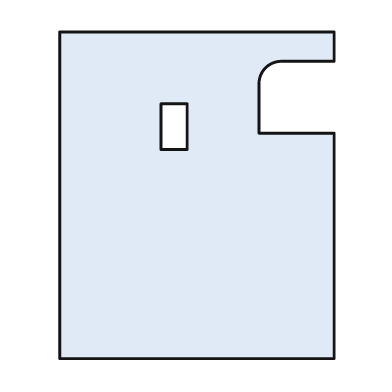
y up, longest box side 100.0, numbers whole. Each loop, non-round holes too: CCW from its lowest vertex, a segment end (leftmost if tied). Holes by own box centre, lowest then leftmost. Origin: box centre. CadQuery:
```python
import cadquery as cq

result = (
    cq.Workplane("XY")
    .moveTo(-42.0, -50.0)
    .lineTo(42.0, -50.0)
    .lineTo(42.0, 19.0)
    .lineTo(19.0, 19.0)
    .lineTo(19.0, 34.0)
    .threePointArc((21.0, 39.0), (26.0, 41.0))
    .lineTo(42.0, 41.0)
    .lineTo(42.0, 50.0)
    .lineTo(-42.0, 50.0)
    .close()
    .moveTo(-11.0, 14.0)
    .lineTo(-3.0, 14.0)
    .lineTo(-3.0, 28.0)
    .lineTo(-11.0, 28.0)
    .close()
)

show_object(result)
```